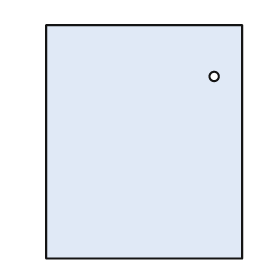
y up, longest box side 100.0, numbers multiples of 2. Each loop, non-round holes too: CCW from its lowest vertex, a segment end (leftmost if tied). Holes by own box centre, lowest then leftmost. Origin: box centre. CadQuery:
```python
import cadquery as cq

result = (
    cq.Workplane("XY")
    .moveTo(-42.0, -50.0)
    .lineTo(42.0, -50.0)
    .lineTo(42.0, 50.0)
    .lineTo(-42.0, 50.0)
    .close()
    .moveTo(30.0, 28.0)
    .circle(2.0)
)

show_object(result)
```